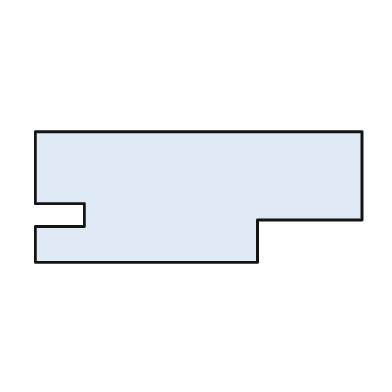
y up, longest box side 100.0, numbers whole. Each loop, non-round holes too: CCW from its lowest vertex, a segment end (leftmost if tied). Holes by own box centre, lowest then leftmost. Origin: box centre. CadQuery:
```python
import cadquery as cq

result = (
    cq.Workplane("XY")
    .moveTo(-50.0, -20.0)
    .lineTo(18.0, -20.0)
    .lineTo(18.0, -7.0)
    .lineTo(50.0, -7.0)
    .lineTo(50.0, 20.0)
    .lineTo(-50.0, 20.0)
    .lineTo(-50.0, -2.0)
    .lineTo(-35.0, -2.0)
    .lineTo(-35.0, -9.0)
    .lineTo(-50.0, -9.0)
    .close()
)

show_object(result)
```